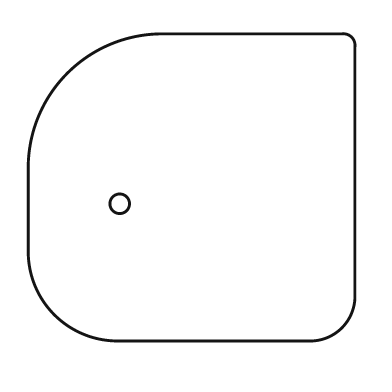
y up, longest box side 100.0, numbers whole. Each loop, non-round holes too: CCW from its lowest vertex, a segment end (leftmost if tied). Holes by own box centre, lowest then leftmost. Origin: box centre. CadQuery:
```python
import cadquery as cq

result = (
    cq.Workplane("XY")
    .moveTo(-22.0, -47.0)
    .lineTo(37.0, -47.0)
    .threePointArc((46.0, -43.0), (50.0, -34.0))
    .lineTo(50.0, 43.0)
    .threePointArc((49.0, 46.0), (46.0, 47.0))
    .lineTo(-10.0, 47.0)
    .threePointArc((-38.0, 35.0), (-50.0, 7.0))
    .lineTo(-50.0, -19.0)
    .threePointArc((-42.0, -39.0), (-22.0, -47.0))
    .close()
    .moveTo(-22.0, -5.0)
    .circle(3.0)
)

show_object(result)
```